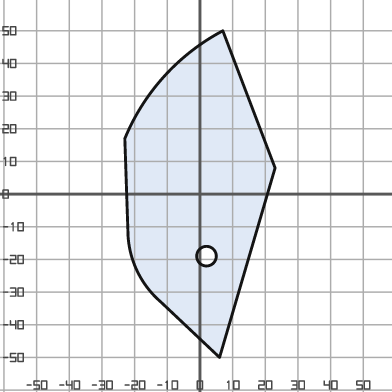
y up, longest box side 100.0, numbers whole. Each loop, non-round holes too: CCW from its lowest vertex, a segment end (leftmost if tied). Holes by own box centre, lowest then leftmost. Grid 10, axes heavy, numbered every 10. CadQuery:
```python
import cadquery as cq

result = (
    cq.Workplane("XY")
    .moveTo(6.0, -50.0)
    .lineTo(23.0, 8.0)
    .lineTo(7.0, 50.0)
    .threePointArc((-11.0, 36.0), (-23.0, 17.0))
    .lineTo(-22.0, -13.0)
    .threePointArc((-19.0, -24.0), (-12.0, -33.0))
    .close()
    .moveTo(2.0, -19.0)
    .circle(3.0)
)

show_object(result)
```